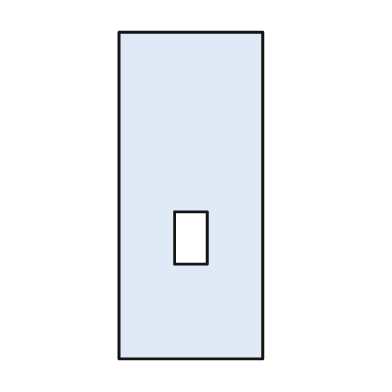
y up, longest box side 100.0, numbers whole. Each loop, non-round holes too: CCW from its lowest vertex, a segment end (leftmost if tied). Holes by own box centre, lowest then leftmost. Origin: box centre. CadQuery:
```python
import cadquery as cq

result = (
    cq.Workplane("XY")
    .moveTo(-22.0, -50.0)
    .lineTo(22.0, -50.0)
    .lineTo(22.0, 50.0)
    .lineTo(-22.0, 50.0)
    .close()
    .moveTo(-5.0, -21.0)
    .lineTo(5.0, -21.0)
    .lineTo(5.0, -5.0)
    .lineTo(-5.0, -5.0)
    .close()
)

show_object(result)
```